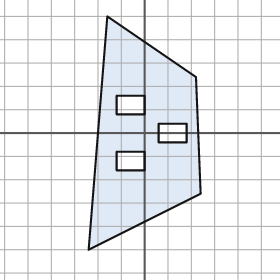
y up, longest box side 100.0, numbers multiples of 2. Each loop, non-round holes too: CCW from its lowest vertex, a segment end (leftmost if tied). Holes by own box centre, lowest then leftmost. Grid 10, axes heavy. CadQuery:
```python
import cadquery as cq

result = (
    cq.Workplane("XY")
    .moveTo(-24.0, -50.0)
    .lineTo(24.0, -26.0)
    .lineTo(22.0, 24.0)
    .lineTo(-16.0, 50.0)
    .close()
    .moveTo(-12.0, -16.0)
    .lineTo(0.0, -16.0)
    .lineTo(0.0, -8.0)
    .lineTo(-12.0, -8.0)
    .close()
    .moveTo(6.0, -4.0)
    .lineTo(18.0, -4.0)
    .lineTo(18.0, 4.0)
    .lineTo(6.0, 4.0)
    .close()
    .moveTo(-12.0, 8.0)
    .lineTo(0.0, 8.0)
    .lineTo(0.0, 16.0)
    .lineTo(-12.0, 16.0)
    .close()
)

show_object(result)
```